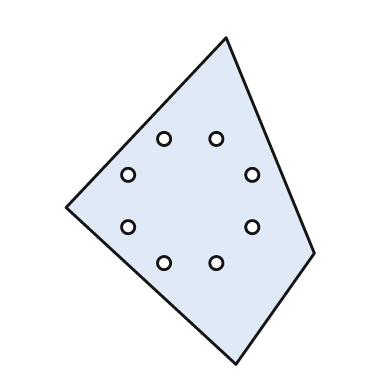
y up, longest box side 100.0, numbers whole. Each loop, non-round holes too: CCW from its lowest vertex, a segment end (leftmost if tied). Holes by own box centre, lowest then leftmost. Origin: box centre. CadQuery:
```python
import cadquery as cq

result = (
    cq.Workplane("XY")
    .moveTo(14.0, -50.0)
    .lineTo(38.0, -16.0)
    .lineTo(11.0, 50.0)
    .lineTo(-38.0, -2.0)
    .close()
    .moveTo(-8.0, -19.0)
    .circle(2.0)
    .moveTo(8.0, -19.0)
    .circle(2.0)
    .moveTo(-19.0, -8.0)
    .circle(2.0)
    .moveTo(19.0, -8.0)
    .circle(2.0)
    .moveTo(-19.0, 8.0)
    .circle(2.0)
    .moveTo(19.0, 8.0)
    .circle(2.0)
    .moveTo(-8.0, 19.0)
    .circle(2.0)
    .moveTo(8.0, 19.0)
    .circle(2.0)
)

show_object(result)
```